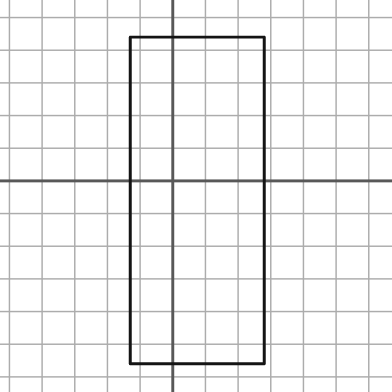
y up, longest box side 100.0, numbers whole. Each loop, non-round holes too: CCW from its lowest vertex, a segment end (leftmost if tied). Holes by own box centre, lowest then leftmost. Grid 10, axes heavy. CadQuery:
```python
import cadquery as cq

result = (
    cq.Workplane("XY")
    .moveTo(-13.0, -56.0)
    .lineTo(28.0, -56.0)
    .lineTo(28.0, 44.0)
    .lineTo(-13.0, 44.0)
    .close()
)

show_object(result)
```